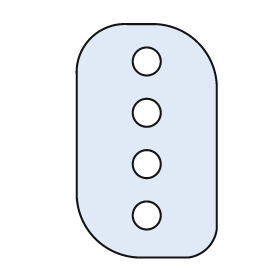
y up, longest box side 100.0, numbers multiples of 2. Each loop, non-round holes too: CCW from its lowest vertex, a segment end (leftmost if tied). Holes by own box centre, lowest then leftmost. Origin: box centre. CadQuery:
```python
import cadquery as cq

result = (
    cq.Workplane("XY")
    .moveTo(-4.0, -50.0)
    .lineTo(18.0, -50.0)
    .threePointArc((26.0, -46.0), (30.0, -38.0))
    .lineTo(30.0, 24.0)
    .threePointArc((22.0, 42.0), (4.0, 50.0))
    .lineTo(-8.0, 50.0)
    .threePointArc((-24.0, 44.0), (-30.0, 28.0))
    .lineTo(-30.0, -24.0)
    .threePointArc((-22.0, -42.0), (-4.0, -50.0))
    .close()
    .moveTo(0.0, -32.0)
    .circle(6.0)
    .moveTo(0.0, -10.0)
    .circle(6.0)
    .moveTo(0.0, 12.0)
    .circle(6.0)
    .moveTo(0.0, 34.0)
    .circle(6.0)
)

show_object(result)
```